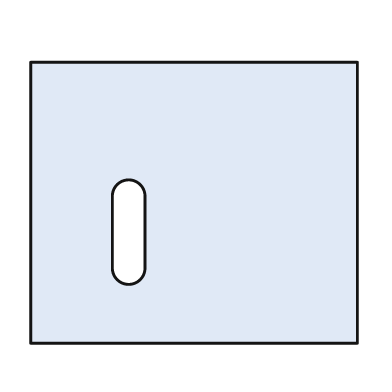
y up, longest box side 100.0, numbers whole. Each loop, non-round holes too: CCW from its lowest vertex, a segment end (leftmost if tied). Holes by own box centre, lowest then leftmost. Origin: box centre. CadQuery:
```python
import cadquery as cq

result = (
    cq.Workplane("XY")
    .moveTo(-50.0, -43.0)
    .lineTo(50.0, -43.0)
    .lineTo(50.0, 43.0)
    .lineTo(-50.0, 43.0)
    .close()
    .moveTo(-25.0, -20.0)
    .threePointArc((-20.0, -25.0), (-15.0, -20.0))
    .lineTo(-15.0, 2.0)
    .threePointArc((-20.0, 7.0), (-25.0, 2.0))
    .close()
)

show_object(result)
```